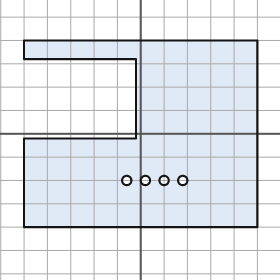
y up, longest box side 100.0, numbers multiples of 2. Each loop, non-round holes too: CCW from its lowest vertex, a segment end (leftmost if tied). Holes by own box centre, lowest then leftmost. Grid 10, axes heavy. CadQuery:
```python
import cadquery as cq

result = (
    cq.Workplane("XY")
    .moveTo(-50.0, -40.0)
    .lineTo(50.0, -40.0)
    .lineTo(50.0, 40.0)
    .lineTo(-50.0, 40.0)
    .lineTo(-50.0, 32.0)
    .lineTo(-2.0, 32.0)
    .lineTo(-2.0, -2.0)
    .lineTo(-50.0, -2.0)
    .close()
    .moveTo(-6.0, -20.0)
    .circle(2.0)
    .moveTo(2.0, -20.0)
    .circle(2.0)
    .moveTo(10.0, -20.0)
    .circle(2.0)
    .moveTo(18.0, -20.0)
    .circle(2.0)
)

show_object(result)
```